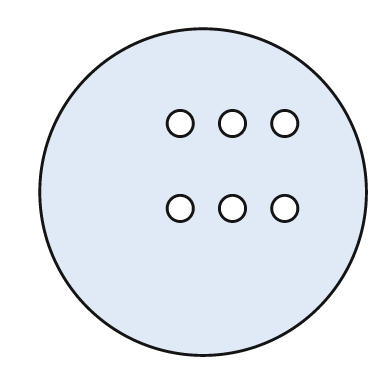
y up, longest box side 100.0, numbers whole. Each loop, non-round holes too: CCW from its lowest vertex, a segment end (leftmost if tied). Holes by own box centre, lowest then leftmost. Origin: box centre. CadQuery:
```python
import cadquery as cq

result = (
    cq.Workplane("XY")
    .moveTo(0.0, 0.0)
    .circle(50.0)
    .moveTo(-7.0, -5.0)
    .circle(4.0)
    .moveTo(9.0, -5.0)
    .circle(4.0)
    .moveTo(25.0, -5.0)
    .circle(4.0)
    .moveTo(-7.0, 21.0)
    .circle(4.0)
    .moveTo(9.0, 21.0)
    .circle(4.0)
    .moveTo(25.0, 21.0)
    .circle(4.0)
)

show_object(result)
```